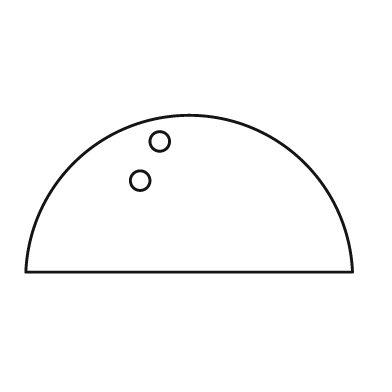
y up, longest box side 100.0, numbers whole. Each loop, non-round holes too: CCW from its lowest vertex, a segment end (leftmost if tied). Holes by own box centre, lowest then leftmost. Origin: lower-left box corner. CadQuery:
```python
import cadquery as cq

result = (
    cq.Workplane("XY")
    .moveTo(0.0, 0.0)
    .lineTo(100.0, 0.0)
    .threePointArc((50.0, 48.0), (0.0, 0.0))
    .close()
    .moveTo(35.0, 28.0)
    .circle(3.0)
    .moveTo(41.0, 40.0)
    .circle(3.0)
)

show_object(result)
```